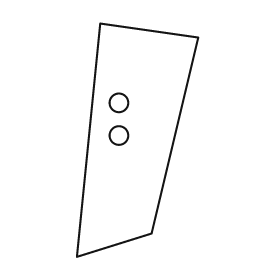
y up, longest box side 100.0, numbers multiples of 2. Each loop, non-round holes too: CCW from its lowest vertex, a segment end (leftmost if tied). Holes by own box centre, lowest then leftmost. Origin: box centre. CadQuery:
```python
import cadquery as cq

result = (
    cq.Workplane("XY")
    .moveTo(-26.0, -50.0)
    .lineTo(6.0, -40.0)
    .lineTo(26.0, 44.0)
    .lineTo(-16.0, 50.0)
    .close()
    .moveTo(-8.0, 2.0)
    .circle(4.0)
    .moveTo(-8.0, 16.0)
    .circle(4.0)
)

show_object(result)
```